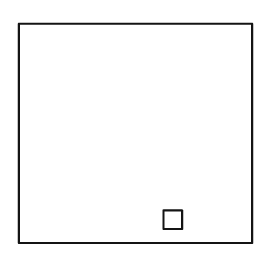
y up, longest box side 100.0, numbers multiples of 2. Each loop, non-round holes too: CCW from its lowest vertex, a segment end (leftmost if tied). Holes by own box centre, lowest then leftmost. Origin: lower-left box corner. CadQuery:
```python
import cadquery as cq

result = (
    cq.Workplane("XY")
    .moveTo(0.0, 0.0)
    .lineTo(100.0, 0.0)
    .lineTo(100.0, 94.0)
    .lineTo(0.0, 94.0)
    .close()
    .moveTo(62.0, 6.0)
    .lineTo(70.0, 6.0)
    .lineTo(70.0, 14.0)
    .lineTo(62.0, 14.0)
    .close()
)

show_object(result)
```